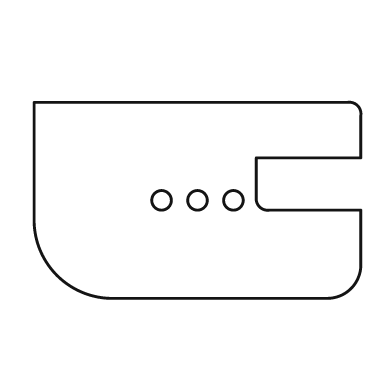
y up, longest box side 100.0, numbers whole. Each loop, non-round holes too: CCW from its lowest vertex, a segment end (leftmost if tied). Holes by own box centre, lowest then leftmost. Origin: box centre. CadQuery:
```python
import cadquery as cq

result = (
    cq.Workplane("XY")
    .moveTo(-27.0, -30.0)
    .lineTo(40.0, -30.0)
    .threePointArc((47.0, -27.0), (50.0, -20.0))
    .lineTo(50.0, -3.0)
    .lineTo(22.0, -3.0)
    .threePointArc((19.0, -2.0), (18.0, 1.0))
    .lineTo(18.0, 13.0)
    .lineTo(50.0, 13.0)
    .lineTo(50.0, 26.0)
    .threePointArc((49.0, 29.0), (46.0, 30.0))
    .lineTo(-50.0, 30.0)
    .lineTo(-50.0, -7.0)
    .threePointArc((-43.0, -23.0), (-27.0, -30.0))
    .close()
    .moveTo(-11.0, 0.0)
    .circle(3.0)
    .moveTo(0.0, 0.0)
    .circle(3.0)
    .moveTo(11.0, 0.0)
    .circle(3.0)
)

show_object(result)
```